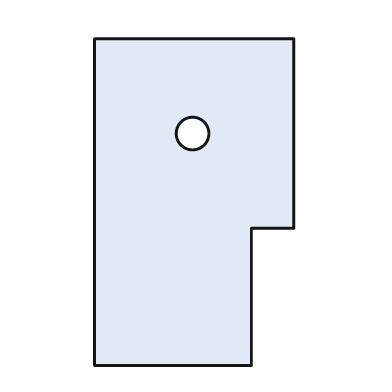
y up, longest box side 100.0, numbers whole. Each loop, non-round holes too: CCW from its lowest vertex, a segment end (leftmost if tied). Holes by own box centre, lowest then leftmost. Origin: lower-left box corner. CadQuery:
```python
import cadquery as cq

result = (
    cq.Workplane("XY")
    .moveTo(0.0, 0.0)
    .lineTo(48.0, 0.0)
    .lineTo(48.0, 42.0)
    .lineTo(61.0, 42.0)
    .lineTo(61.0, 100.0)
    .lineTo(0.0, 100.0)
    .close()
    .moveTo(30.0, 71.0)
    .circle(5.0)
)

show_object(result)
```